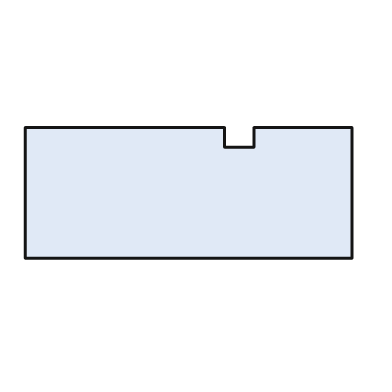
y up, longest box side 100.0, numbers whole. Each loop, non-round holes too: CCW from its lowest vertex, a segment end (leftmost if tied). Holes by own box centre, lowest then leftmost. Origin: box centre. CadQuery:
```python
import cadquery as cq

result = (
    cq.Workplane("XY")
    .moveTo(-50.0, -20.0)
    .lineTo(50.0, -20.0)
    .lineTo(50.0, 20.0)
    .lineTo(20.0, 20.0)
    .lineTo(20.0, 14.0)
    .lineTo(11.0, 14.0)
    .lineTo(11.0, 20.0)
    .lineTo(-50.0, 20.0)
    .close()
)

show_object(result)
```